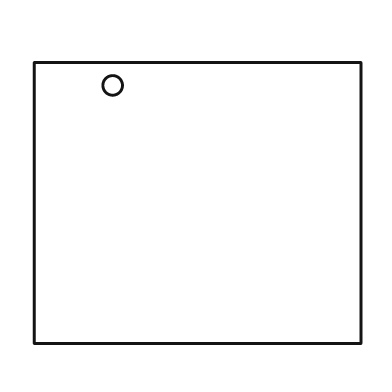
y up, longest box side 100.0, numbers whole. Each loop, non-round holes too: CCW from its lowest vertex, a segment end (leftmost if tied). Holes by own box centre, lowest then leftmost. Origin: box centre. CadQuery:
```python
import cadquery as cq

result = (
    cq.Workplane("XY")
    .moveTo(-50.0, -43.0)
    .lineTo(50.0, -43.0)
    .lineTo(50.0, 43.0)
    .lineTo(-50.0, 43.0)
    .close()
    .moveTo(-26.0, 36.0)
    .circle(3.0)
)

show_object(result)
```